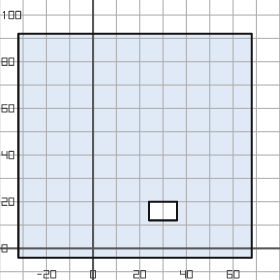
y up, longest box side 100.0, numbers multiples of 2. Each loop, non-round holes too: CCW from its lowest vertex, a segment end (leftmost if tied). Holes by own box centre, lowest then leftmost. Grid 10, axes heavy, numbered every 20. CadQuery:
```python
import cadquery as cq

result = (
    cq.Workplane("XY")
    .moveTo(-32.0, -4.0)
    .lineTo(68.0, -4.0)
    .lineTo(68.0, 92.0)
    .lineTo(-32.0, 92.0)
    .close()
    .moveTo(24.0, 12.0)
    .lineTo(36.0, 12.0)
    .lineTo(36.0, 20.0)
    .lineTo(24.0, 20.0)
    .close()
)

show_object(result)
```